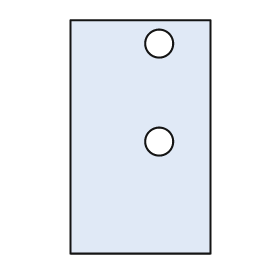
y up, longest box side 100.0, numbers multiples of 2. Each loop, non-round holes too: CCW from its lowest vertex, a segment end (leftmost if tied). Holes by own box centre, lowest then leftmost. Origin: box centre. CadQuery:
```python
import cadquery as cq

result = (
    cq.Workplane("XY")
    .moveTo(-30.0, -50.0)
    .lineTo(30.0, -50.0)
    .lineTo(30.0, 50.0)
    .lineTo(-30.0, 50.0)
    .close()
    .moveTo(8.0, -2.0)
    .circle(6.0)
    .moveTo(8.0, 40.0)
    .circle(6.0)
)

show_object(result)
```